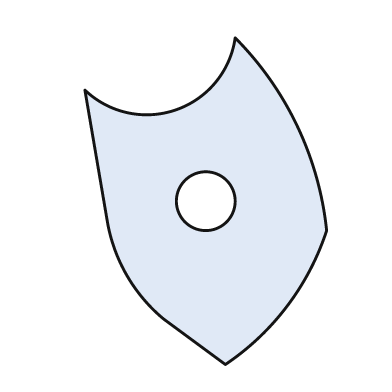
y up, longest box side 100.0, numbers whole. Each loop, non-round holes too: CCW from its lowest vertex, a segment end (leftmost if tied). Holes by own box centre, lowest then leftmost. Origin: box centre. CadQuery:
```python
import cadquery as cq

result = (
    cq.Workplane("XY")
    .moveTo(6.0, -50.0)
    .threePointArc((25.0, -32.0), (37.0, -9.0))
    .threePointArc((28.0, 23.0), (9.0, 50.0))
    .threePointArc((-9.0, 28.0), (-37.0, 34.0))
    .lineTo(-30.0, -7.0)
    .threePointArc((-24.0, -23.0), (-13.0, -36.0))
    .close()
    .moveTo(0.0, 0.0)
    .circle(9.0)
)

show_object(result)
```